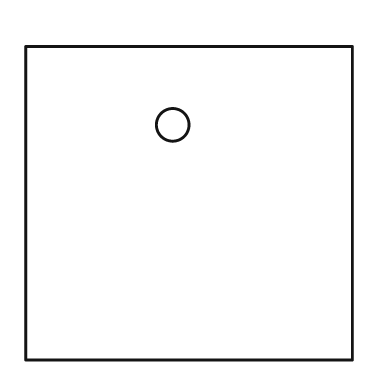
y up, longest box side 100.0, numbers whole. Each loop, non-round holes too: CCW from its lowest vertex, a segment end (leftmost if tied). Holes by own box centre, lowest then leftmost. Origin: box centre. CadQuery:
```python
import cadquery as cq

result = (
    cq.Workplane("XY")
    .moveTo(-50.0, -48.0)
    .lineTo(50.0, -48.0)
    .lineTo(50.0, 48.0)
    .lineTo(-50.0, 48.0)
    .close()
    .moveTo(-5.0, 24.0)
    .circle(5.0)
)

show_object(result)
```